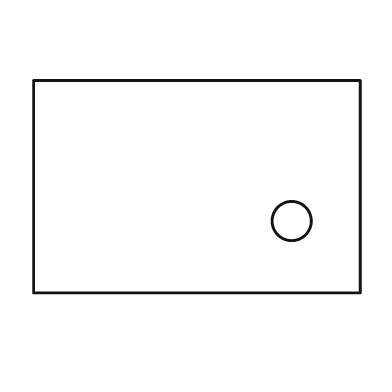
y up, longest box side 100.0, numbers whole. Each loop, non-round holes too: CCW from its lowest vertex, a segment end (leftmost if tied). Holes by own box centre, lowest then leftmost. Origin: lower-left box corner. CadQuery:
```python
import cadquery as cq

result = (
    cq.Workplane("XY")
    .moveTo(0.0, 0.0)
    .lineTo(100.0, 0.0)
    .lineTo(100.0, 65.0)
    .lineTo(0.0, 65.0)
    .close()
    .moveTo(79.0, 22.0)
    .circle(6.0)
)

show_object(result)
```